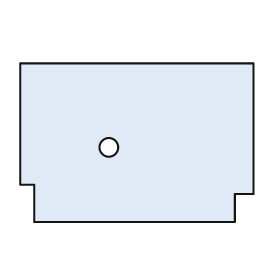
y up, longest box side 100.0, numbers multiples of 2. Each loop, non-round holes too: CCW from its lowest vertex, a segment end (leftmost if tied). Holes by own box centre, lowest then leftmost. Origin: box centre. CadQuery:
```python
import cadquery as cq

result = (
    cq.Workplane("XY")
    .moveTo(-44.0, -34.0)
    .lineTo(42.0, -34.0)
    .lineTo(42.0, -22.0)
    .lineTo(50.0, -22.0)
    .lineTo(50.0, 34.0)
    .lineTo(-50.0, 34.0)
    .lineTo(-50.0, -18.0)
    .lineTo(-44.0, -18.0)
    .close()
    .moveTo(-12.0, -2.0)
    .circle(4.0)
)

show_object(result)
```